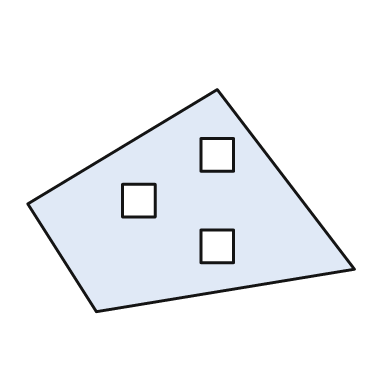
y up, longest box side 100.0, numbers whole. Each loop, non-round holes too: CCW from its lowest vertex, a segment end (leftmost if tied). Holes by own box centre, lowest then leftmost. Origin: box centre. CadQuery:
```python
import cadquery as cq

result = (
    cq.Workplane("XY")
    .moveTo(-29.0, -34.0)
    .lineTo(50.0, -21.0)
    .lineTo(8.0, 34.0)
    .lineTo(-50.0, -1.0)
    .close()
    .moveTo(3.0, -19.0)
    .lineTo(13.0, -19.0)
    .lineTo(13.0, -9.0)
    .lineTo(3.0, -9.0)
    .close()
    .moveTo(-21.0, -5.0)
    .lineTo(-11.0, -5.0)
    .lineTo(-11.0, 5.0)
    .lineTo(-21.0, 5.0)
    .close()
    .moveTo(3.0, 9.0)
    .lineTo(13.0, 9.0)
    .lineTo(13.0, 19.0)
    .lineTo(3.0, 19.0)
    .close()
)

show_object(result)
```